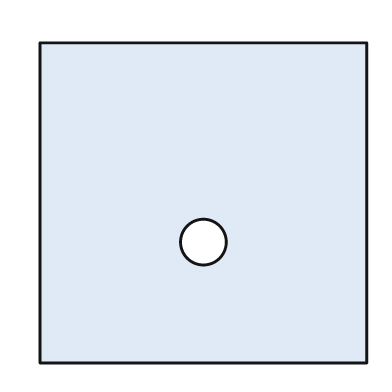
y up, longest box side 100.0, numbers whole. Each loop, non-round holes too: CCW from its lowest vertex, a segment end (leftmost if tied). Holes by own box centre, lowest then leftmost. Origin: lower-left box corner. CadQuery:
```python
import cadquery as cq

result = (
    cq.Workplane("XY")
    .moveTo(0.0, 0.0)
    .lineTo(100.0, 0.0)
    .lineTo(100.0, 98.0)
    .lineTo(0.0, 98.0)
    .close()
    .moveTo(50.0, 37.0)
    .circle(7.0)
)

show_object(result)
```